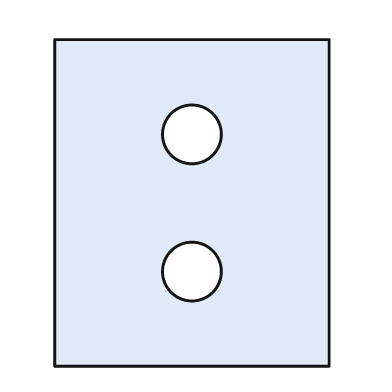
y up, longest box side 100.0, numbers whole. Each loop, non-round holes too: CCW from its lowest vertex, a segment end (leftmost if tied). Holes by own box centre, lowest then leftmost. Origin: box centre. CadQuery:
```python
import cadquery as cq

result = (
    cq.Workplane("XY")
    .moveTo(-42.0, -50.0)
    .lineTo(42.0, -50.0)
    .lineTo(42.0, 50.0)
    .lineTo(-42.0, 50.0)
    .close()
    .moveTo(0.0, -21.0)
    .circle(9.0)
    .moveTo(0.0, 21.0)
    .circle(9.0)
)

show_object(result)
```